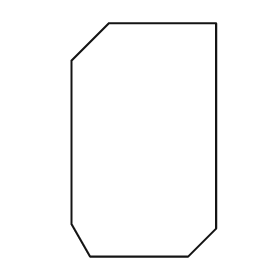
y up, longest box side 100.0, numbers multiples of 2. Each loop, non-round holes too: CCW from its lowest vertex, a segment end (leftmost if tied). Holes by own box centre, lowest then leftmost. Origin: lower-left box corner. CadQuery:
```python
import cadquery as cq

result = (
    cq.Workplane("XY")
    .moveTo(8.0, 0.0)
    .lineTo(50.0, 0.0)
    .lineTo(62.0, 12.0)
    .lineTo(62.0, 100.0)
    .lineTo(16.0, 100.0)
    .lineTo(0.0, 84.0)
    .lineTo(0.0, 14.0)
    .close()
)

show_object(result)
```